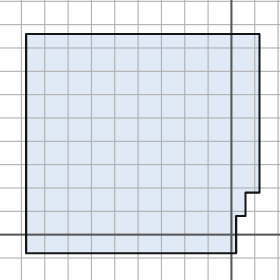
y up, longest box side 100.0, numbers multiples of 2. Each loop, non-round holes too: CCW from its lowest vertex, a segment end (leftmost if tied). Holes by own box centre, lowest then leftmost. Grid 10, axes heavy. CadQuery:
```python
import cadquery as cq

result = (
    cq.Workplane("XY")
    .moveTo(-88.0, -8.0)
    .lineTo(2.0, -8.0)
    .lineTo(2.0, 8.0)
    .lineTo(6.0, 8.0)
    .lineTo(6.0, 18.0)
    .lineTo(12.0, 18.0)
    .lineTo(12.0, 86.0)
    .lineTo(-88.0, 86.0)
    .close()
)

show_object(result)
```